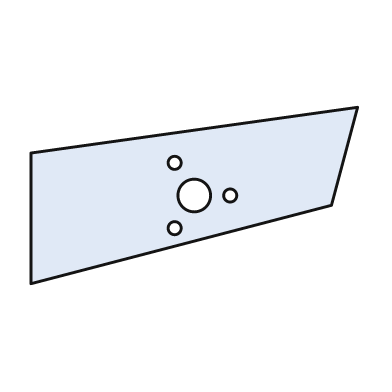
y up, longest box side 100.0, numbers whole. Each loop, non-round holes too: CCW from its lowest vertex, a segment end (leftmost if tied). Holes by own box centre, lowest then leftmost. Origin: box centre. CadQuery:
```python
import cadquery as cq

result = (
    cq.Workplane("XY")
    .moveTo(-50.0, -27.0)
    .lineTo(42.0, -3.0)
    .lineTo(50.0, 27.0)
    .lineTo(-50.0, 13.0)
    .close()
    .moveTo(-6.0, -10.0)
    .circle(2.0)
    .moveTo(0.0, 0.0)
    .circle(5.0)
    .moveTo(11.0, 0.0)
    .circle(2.0)
    .moveTo(-6.0, 10.0)
    .circle(2.0)
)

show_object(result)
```